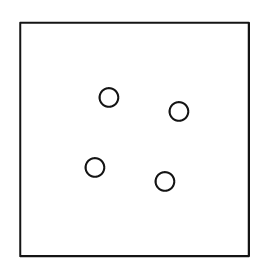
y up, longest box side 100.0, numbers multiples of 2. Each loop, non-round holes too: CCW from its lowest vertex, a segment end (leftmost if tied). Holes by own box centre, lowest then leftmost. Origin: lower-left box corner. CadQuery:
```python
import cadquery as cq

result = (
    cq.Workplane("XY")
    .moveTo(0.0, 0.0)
    .lineTo(98.0, 0.0)
    .lineTo(98.0, 100.0)
    .lineTo(0.0, 100.0)
    .close()
    .moveTo(62.0, 32.0)
    .circle(4.0)
    .moveTo(32.0, 38.0)
    .circle(4.0)
    .moveTo(68.0, 62.0)
    .circle(4.0)
    .moveTo(38.0, 68.0)
    .circle(4.0)
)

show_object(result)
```